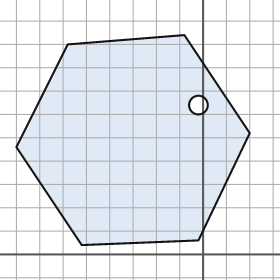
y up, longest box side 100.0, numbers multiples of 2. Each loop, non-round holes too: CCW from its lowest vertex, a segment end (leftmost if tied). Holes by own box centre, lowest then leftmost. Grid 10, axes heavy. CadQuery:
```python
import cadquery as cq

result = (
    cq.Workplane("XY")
    .moveTo(-52.0, 4.0)
    .lineTo(-2.0, 6.0)
    .lineTo(20.0, 52.0)
    .lineTo(-8.0, 94.0)
    .lineTo(-58.0, 90.0)
    .lineTo(-80.0, 46.0)
    .close()
    .moveTo(-2.0, 64.0)
    .circle(4.0)
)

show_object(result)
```